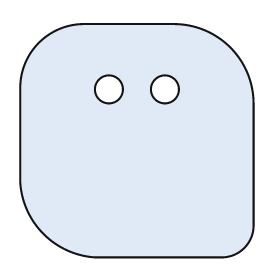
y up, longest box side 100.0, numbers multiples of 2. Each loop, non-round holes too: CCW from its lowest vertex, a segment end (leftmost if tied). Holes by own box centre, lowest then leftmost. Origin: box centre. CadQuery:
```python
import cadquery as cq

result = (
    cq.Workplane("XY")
    .moveTo(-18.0, -50.0)
    .lineTo(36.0, -50.0)
    .threePointArc((46.0, -46.0), (50.0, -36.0))
    .lineTo(50.0, 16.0)
    .threePointArc((40.0, 40.0), (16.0, 50.0))
    .lineTo(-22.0, 50.0)
    .threePointArc((-42.0, 42.0), (-50.0, 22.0))
    .lineTo(-50.0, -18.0)
    .threePointArc((-40.0, -40.0), (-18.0, -50.0))
    .close()
    .moveTo(-12.0, 22.0)
    .circle(6.0)
    .moveTo(12.0, 22.0)
    .circle(6.0)
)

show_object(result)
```